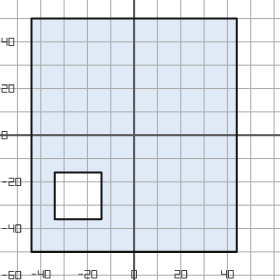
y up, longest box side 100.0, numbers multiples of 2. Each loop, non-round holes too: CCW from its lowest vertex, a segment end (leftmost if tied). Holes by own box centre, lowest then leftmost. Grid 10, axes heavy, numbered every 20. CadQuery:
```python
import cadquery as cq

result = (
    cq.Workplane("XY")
    .moveTo(-44.0, -50.0)
    .lineTo(44.0, -50.0)
    .lineTo(44.0, 50.0)
    .lineTo(-44.0, 50.0)
    .close()
    .moveTo(-34.0, -36.0)
    .lineTo(-14.0, -36.0)
    .lineTo(-14.0, -16.0)
    .lineTo(-34.0, -16.0)
    .close()
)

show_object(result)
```